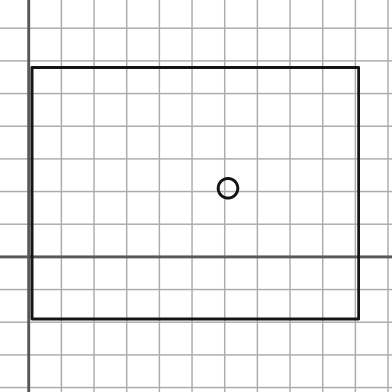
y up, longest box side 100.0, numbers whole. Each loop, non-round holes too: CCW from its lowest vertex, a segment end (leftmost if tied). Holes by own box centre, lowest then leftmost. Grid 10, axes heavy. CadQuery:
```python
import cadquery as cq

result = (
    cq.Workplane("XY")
    .moveTo(1.0, -19.0)
    .lineTo(101.0, -19.0)
    .lineTo(101.0, 58.0)
    .lineTo(1.0, 58.0)
    .close()
    .moveTo(61.0, 21.0)
    .circle(3.0)
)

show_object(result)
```